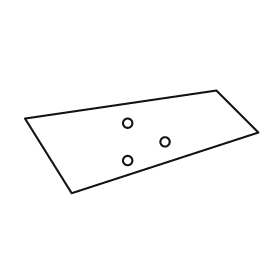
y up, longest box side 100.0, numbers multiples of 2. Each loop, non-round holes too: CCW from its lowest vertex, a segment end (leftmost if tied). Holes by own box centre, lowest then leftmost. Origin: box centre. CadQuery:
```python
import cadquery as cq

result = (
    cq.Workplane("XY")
    .moveTo(-30.0, -22.0)
    .lineTo(50.0, 4.0)
    .lineTo(32.0, 22.0)
    .lineTo(-50.0, 10.0)
    .close()
    .moveTo(-6.0, -8.0)
    .circle(2.0)
    .moveTo(10.0, 0.0)
    .circle(2.0)
    .moveTo(-6.0, 8.0)
    .circle(2.0)
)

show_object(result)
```